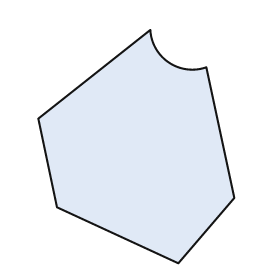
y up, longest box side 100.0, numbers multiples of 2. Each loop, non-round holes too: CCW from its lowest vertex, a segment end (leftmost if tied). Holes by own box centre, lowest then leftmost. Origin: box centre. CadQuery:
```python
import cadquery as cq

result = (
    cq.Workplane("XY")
    .moveTo(18.0, -50.0)
    .lineTo(42.0, -22.0)
    .lineTo(30.0, 34.0)
    .threePointArc((14.0, 36.0), (6.0, 50.0))
    .lineTo(-42.0, 12.0)
    .lineTo(-34.0, -26.0)
    .close()
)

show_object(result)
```